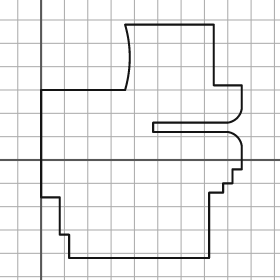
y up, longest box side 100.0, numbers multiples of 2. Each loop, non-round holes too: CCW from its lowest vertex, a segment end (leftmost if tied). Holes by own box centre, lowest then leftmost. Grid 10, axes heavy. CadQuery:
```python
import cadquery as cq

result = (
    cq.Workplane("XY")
    .moveTo(12.0, -42.0)
    .lineTo(72.0, -42.0)
    .lineTo(72.0, -14.0)
    .lineTo(78.0, -14.0)
    .lineTo(78.0, -10.0)
    .lineTo(82.0, -10.0)
    .lineTo(82.0, -4.0)
    .lineTo(86.0, -4.0)
    .lineTo(86.0, 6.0)
    .threePointArc((84.0, 10.0), (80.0, 12.0))
    .lineTo(48.0, 12.0)
    .lineTo(48.0, 16.0)
    .lineTo(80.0, 16.0)
    .threePointArc((84.0, 18.0), (86.0, 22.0))
    .lineTo(86.0, 32.0)
    .lineTo(74.0, 32.0)
    .lineTo(74.0, 58.0)
    .lineTo(36.0, 58.0)
    .threePointArc((38.0, 44.0), (36.0, 30.0))
    .lineTo(0.0, 30.0)
    .lineTo(0.0, -16.0)
    .lineTo(8.0, -16.0)
    .lineTo(8.0, -32.0)
    .lineTo(12.0, -32.0)
    .close()
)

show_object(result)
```